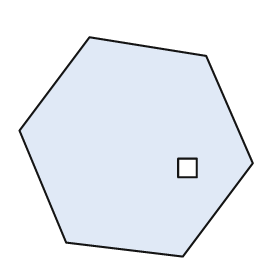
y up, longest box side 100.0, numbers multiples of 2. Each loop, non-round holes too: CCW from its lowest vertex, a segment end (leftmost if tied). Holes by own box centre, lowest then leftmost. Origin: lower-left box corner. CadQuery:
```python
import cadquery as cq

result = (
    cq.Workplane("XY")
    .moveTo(70.0, 0.0)
    .lineTo(100.0, 40.0)
    .lineTo(80.0, 86.0)
    .lineTo(30.0, 94.0)
    .lineTo(0.0, 54.0)
    .lineTo(20.0, 6.0)
    .close()
    .moveTo(68.0, 34.0)
    .lineTo(76.0, 34.0)
    .lineTo(76.0, 42.0)
    .lineTo(68.0, 42.0)
    .close()
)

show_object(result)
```